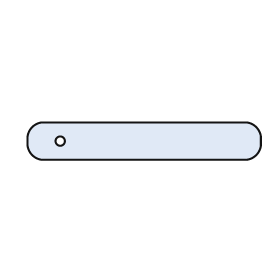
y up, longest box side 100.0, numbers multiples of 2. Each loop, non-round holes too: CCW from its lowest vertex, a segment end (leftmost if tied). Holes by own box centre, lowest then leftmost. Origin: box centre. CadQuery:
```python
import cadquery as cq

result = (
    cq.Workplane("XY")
    .moveTo(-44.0, -8.0)
    .lineTo(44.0, -8.0)
    .threePointArc((48.0, -6.0), (50.0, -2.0))
    .lineTo(50.0, 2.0)
    .threePointArc((48.0, 6.0), (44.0, 8.0))
    .lineTo(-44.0, 8.0)
    .threePointArc((-48.0, 6.0), (-50.0, 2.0))
    .lineTo(-50.0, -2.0)
    .threePointArc((-48.0, -6.0), (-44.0, -8.0))
    .close()
    .moveTo(-36.0, 0.0)
    .circle(2.0)
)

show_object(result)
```